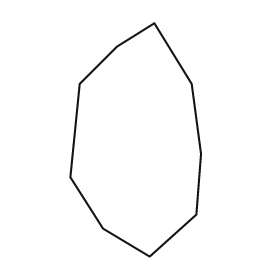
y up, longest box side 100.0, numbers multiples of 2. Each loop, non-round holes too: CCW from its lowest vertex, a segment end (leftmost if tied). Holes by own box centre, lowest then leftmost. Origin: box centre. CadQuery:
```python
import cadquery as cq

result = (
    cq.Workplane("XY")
    .moveTo(6.0, -50.0)
    .lineTo(26.0, -32.0)
    .lineTo(28.0, -6.0)
    .lineTo(24.0, 24.0)
    .lineTo(8.0, 50.0)
    .lineTo(-8.0, 40.0)
    .lineTo(-24.0, 24.0)
    .lineTo(-28.0, -16.0)
    .lineTo(-14.0, -38.0)
    .close()
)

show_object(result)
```